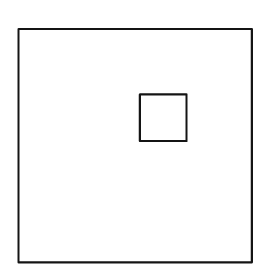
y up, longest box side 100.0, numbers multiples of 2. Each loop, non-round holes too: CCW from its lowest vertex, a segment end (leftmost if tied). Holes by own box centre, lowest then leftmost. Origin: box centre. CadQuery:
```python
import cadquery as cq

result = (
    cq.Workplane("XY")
    .moveTo(-50.0, -50.0)
    .lineTo(50.0, -50.0)
    .lineTo(50.0, 50.0)
    .lineTo(-50.0, 50.0)
    .close()
    .moveTo(2.0, 2.0)
    .lineTo(22.0, 2.0)
    .lineTo(22.0, 22.0)
    .lineTo(2.0, 22.0)
    .close()
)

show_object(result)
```